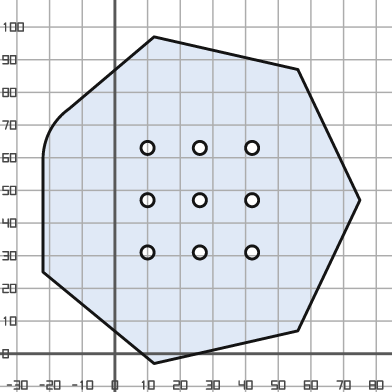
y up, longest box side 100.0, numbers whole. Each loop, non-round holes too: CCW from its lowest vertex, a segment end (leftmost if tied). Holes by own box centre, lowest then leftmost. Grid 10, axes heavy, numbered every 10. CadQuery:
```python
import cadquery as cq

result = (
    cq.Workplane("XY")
    .moveTo(12.0, -3.0)
    .lineTo(56.0, 7.0)
    .lineTo(75.0, 47.0)
    .lineTo(56.0, 87.0)
    .lineTo(12.0, 97.0)
    .lineTo(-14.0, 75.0)
    .threePointArc((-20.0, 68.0), (-22.0, 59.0))
    .lineTo(-22.0, 25.0)
    .close()
    .moveTo(10.0, 31.0)
    .circle(2.0)
    .moveTo(26.0, 31.0)
    .circle(2.0)
    .moveTo(42.0, 31.0)
    .circle(2.0)
    .moveTo(10.0, 47.0)
    .circle(2.0)
    .moveTo(26.0, 47.0)
    .circle(2.0)
    .moveTo(42.0, 47.0)
    .circle(2.0)
    .moveTo(10.0, 63.0)
    .circle(2.0)
    .moveTo(26.0, 63.0)
    .circle(2.0)
    .moveTo(42.0, 63.0)
    .circle(2.0)
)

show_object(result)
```